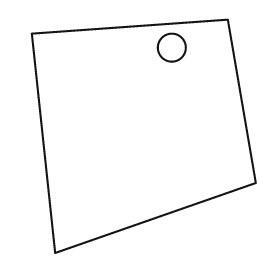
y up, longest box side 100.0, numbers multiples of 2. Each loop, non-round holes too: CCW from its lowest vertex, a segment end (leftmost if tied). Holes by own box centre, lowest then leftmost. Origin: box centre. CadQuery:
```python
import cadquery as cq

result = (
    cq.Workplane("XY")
    .moveTo(-38.0, -50.0)
    .lineTo(48.0, -20.0)
    .lineTo(36.0, 50.0)
    .lineTo(-48.0, 44.0)
    .close()
    .moveTo(12.0, 38.0)
    .circle(6.0)
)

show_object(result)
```